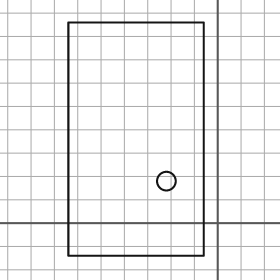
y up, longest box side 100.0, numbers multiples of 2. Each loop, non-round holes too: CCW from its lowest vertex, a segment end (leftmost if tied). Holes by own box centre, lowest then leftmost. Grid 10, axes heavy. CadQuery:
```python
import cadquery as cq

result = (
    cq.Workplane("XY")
    .moveTo(-64.0, -14.0)
    .lineTo(-6.0, -14.0)
    .lineTo(-6.0, 86.0)
    .lineTo(-64.0, 86.0)
    .close()
    .moveTo(-22.0, 18.0)
    .circle(4.0)
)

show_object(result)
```